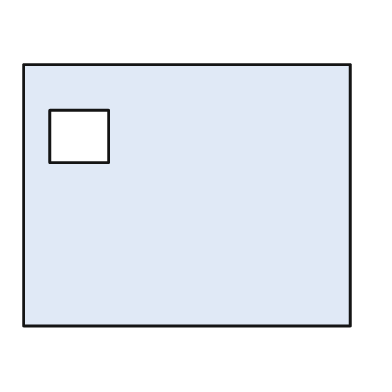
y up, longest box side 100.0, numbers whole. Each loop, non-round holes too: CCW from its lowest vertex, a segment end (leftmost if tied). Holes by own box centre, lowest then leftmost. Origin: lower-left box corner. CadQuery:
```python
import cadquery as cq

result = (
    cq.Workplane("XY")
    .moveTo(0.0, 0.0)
    .lineTo(100.0, 0.0)
    .lineTo(100.0, 80.0)
    .lineTo(0.0, 80.0)
    .close()
    .moveTo(8.0, 50.0)
    .lineTo(26.0, 50.0)
    .lineTo(26.0, 66.0)
    .lineTo(8.0, 66.0)
    .close()
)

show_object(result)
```